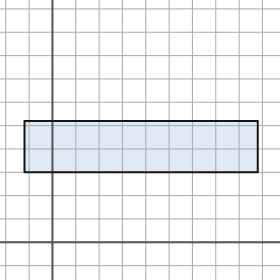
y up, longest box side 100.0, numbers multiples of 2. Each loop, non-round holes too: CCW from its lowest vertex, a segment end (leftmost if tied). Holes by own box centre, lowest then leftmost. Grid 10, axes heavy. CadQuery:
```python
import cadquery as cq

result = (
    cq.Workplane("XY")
    .moveTo(-12.0, 30.0)
    .lineTo(88.0, 30.0)
    .lineTo(88.0, 52.0)
    .lineTo(-12.0, 52.0)
    .close()
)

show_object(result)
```